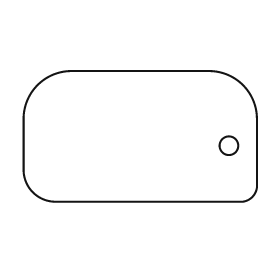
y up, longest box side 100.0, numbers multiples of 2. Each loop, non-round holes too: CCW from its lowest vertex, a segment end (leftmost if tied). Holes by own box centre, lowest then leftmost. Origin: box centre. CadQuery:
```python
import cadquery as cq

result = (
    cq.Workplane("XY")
    .moveTo(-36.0, -28.0)
    .lineTo(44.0, -28.0)
    .threePointArc((48.0, -26.0), (50.0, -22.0))
    .lineTo(50.0, 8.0)
    .threePointArc((44.0, 22.0), (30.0, 28.0))
    .lineTo(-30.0, 28.0)
    .threePointArc((-44.0, 22.0), (-50.0, 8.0))
    .lineTo(-50.0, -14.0)
    .threePointArc((-46.0, -24.0), (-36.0, -28.0))
    .close()
    .moveTo(38.0, -4.0)
    .circle(4.0)
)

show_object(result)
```